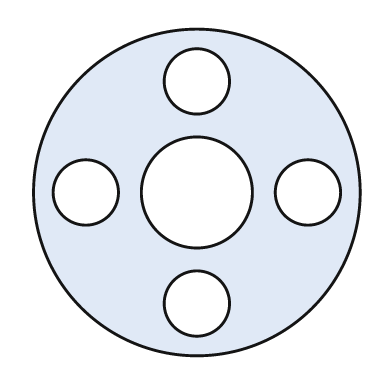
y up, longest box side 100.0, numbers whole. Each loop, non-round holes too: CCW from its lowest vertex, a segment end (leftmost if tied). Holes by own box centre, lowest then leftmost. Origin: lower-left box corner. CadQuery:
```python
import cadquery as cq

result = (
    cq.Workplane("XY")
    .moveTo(50.0, 50.0)
    .circle(50.0)
    .moveTo(50.0, 16.0)
    .circle(10.0)
    .moveTo(16.0, 50.0)
    .circle(10.0)
    .moveTo(50.0, 50.0)
    .circle(17.0)
    .moveTo(84.0, 50.0)
    .circle(10.0)
    .moveTo(50.0, 84.0)
    .circle(10.0)
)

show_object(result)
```